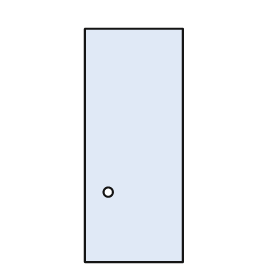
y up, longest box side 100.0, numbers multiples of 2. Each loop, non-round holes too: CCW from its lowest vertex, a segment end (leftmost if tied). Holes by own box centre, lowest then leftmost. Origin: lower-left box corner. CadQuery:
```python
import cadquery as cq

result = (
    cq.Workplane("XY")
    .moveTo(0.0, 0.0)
    .lineTo(42.0, 0.0)
    .lineTo(42.0, 100.0)
    .lineTo(0.0, 100.0)
    .close()
    .moveTo(10.0, 30.0)
    .circle(2.0)
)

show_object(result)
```